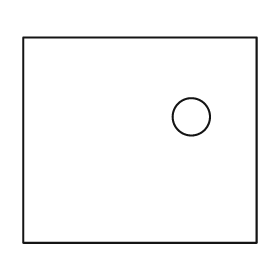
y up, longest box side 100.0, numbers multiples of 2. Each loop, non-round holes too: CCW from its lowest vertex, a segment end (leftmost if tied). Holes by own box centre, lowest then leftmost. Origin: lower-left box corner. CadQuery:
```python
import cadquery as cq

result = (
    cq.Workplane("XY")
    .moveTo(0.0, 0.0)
    .lineTo(100.0, 0.0)
    .lineTo(100.0, 88.0)
    .lineTo(0.0, 88.0)
    .close()
    .moveTo(72.0, 54.0)
    .circle(8.0)
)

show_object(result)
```